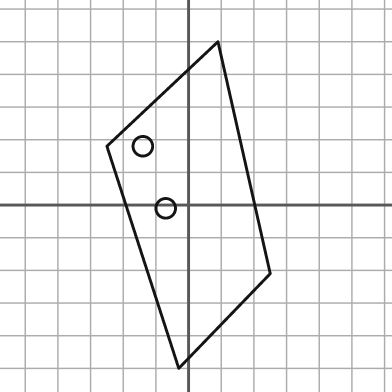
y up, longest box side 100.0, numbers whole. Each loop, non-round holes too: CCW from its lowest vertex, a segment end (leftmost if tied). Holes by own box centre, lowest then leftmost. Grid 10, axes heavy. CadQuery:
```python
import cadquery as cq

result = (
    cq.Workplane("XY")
    .moveTo(-3.0, -50.0)
    .lineTo(25.0, -21.0)
    .lineTo(9.0, 50.0)
    .lineTo(-25.0, 18.0)
    .close()
    .moveTo(-7.0, -1.0)
    .circle(3.0)
    .moveTo(-14.0, 18.0)
    .circle(3.0)
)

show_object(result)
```